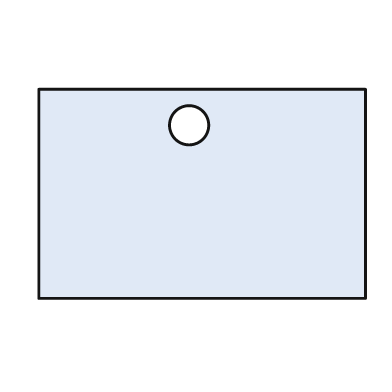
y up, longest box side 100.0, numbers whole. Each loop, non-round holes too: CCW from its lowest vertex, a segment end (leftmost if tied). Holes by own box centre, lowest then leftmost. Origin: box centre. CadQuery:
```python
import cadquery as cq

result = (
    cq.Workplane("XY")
    .moveTo(-50.0, -32.0)
    .lineTo(50.0, -32.0)
    .lineTo(50.0, 32.0)
    .lineTo(-50.0, 32.0)
    .close()
    .moveTo(-4.0, 21.0)
    .circle(6.0)
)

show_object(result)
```